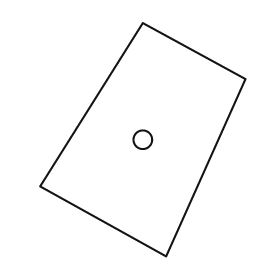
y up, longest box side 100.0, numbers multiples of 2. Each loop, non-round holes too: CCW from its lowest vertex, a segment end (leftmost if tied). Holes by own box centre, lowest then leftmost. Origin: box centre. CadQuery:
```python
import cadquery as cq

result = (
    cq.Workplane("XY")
    .moveTo(10.0, -50.0)
    .lineTo(44.0, 26.0)
    .lineTo(0.0, 50.0)
    .lineTo(-44.0, -20.0)
    .close()
    .moveTo(0.0, 0.0)
    .circle(4.0)
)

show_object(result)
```